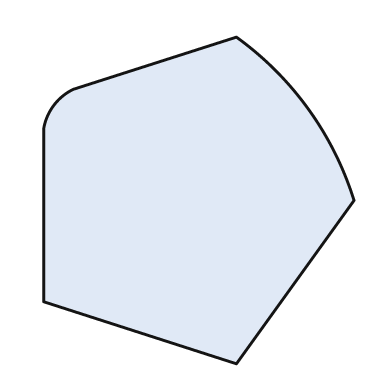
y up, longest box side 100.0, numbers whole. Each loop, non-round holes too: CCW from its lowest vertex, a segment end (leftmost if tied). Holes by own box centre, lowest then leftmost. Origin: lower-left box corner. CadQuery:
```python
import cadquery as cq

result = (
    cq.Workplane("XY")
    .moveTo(59.0, 0.0)
    .lineTo(95.0, 50.0)
    .threePointArc((81.0, 78.0), (59.0, 100.0))
    .lineTo(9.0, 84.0)
    .threePointArc((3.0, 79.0), (0.0, 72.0))
    .lineTo(0.0, 19.0)
    .close()
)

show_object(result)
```